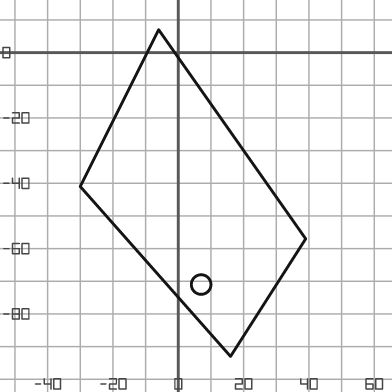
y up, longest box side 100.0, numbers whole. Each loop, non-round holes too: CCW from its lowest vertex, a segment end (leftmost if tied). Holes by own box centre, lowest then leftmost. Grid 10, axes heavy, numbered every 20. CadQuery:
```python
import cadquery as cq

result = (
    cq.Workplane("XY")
    .moveTo(16.0, -93.0)
    .lineTo(39.0, -57.0)
    .lineTo(-6.0, 7.0)
    .lineTo(-30.0, -41.0)
    .close()
    .moveTo(7.0, -71.0)
    .circle(3.0)
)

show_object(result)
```